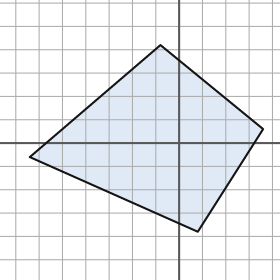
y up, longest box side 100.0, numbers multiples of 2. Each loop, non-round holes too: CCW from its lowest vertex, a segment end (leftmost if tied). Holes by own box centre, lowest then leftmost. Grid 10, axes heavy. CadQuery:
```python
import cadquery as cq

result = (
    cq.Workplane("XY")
    .moveTo(8.0, -38.0)
    .lineTo(36.0, 6.0)
    .lineTo(-8.0, 42.0)
    .lineTo(-64.0, -6.0)
    .close()
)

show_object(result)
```